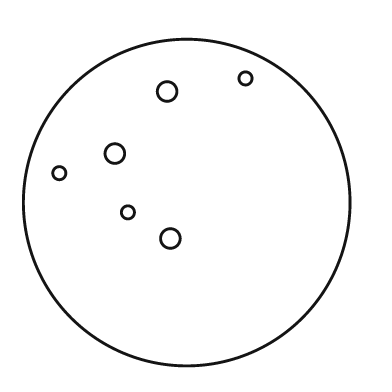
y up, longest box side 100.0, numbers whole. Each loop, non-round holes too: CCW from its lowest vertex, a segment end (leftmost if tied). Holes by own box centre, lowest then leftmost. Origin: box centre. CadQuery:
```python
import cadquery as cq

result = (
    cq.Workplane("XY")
    .moveTo(0.0, 0.0)
    .circle(50.0)
    .moveTo(-5.0, -11.0)
    .circle(3.0)
    .moveTo(-18.0, -3.0)
    .circle(2.0)
    .moveTo(-39.0, 9.0)
    .circle(2.0)
    .moveTo(-22.0, 15.0)
    .circle(3.0)
    .moveTo(-6.0, 34.0)
    .circle(3.0)
    .moveTo(18.0, 38.0)
    .circle(2.0)
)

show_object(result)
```